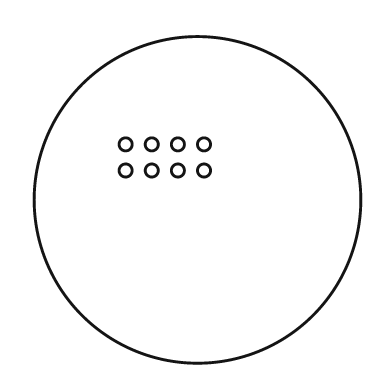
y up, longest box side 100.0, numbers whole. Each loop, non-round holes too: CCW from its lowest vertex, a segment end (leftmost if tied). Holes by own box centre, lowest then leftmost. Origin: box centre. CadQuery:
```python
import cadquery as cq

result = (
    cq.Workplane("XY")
    .moveTo(0.0, 0.0)
    .circle(50.0)
    .moveTo(-22.0, 9.0)
    .circle(2.0)
    .moveTo(-14.0, 9.0)
    .circle(2.0)
    .moveTo(-6.0, 9.0)
    .circle(2.0)
    .moveTo(2.0, 9.0)
    .circle(2.0)
    .moveTo(-22.0, 17.0)
    .circle(2.0)
    .moveTo(-14.0, 17.0)
    .circle(2.0)
    .moveTo(-6.0, 17.0)
    .circle(2.0)
    .moveTo(2.0, 17.0)
    .circle(2.0)
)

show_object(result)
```